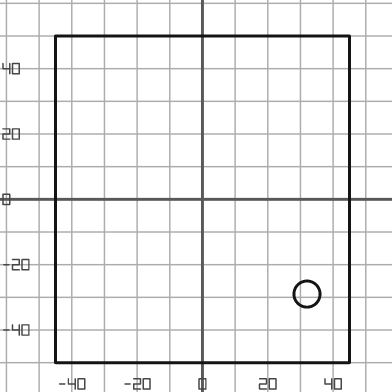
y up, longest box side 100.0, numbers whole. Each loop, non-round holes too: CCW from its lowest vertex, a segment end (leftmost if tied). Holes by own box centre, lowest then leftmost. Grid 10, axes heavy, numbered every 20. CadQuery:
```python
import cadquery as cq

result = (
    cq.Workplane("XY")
    .moveTo(-45.0, -50.0)
    .lineTo(45.0, -50.0)
    .lineTo(45.0, 50.0)
    .lineTo(-45.0, 50.0)
    .close()
    .moveTo(32.0, -29.0)
    .circle(4.0)
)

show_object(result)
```